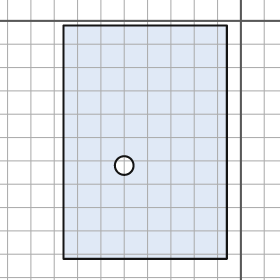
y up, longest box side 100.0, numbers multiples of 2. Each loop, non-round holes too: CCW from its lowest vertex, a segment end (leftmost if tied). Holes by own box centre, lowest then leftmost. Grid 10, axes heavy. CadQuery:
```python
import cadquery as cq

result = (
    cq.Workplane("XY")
    .moveTo(-76.0, -102.0)
    .lineTo(-6.0, -102.0)
    .lineTo(-6.0, -2.0)
    .lineTo(-76.0, -2.0)
    .close()
    .moveTo(-50.0, -62.0)
    .circle(4.0)
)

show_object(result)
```